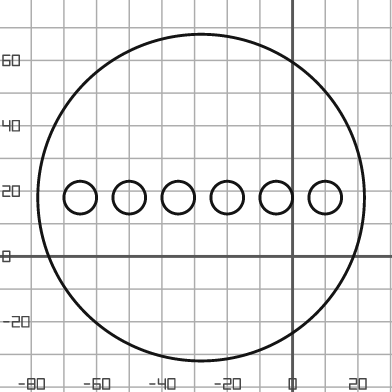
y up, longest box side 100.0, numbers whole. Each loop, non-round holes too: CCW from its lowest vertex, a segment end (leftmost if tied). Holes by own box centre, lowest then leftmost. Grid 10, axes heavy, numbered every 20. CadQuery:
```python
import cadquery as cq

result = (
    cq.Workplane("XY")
    .moveTo(-28.0, 18.0)
    .circle(50.0)
    .moveTo(-65.0, 18.0)
    .circle(5.0)
    .moveTo(-50.0, 18.0)
    .circle(5.0)
    .moveTo(-35.0, 18.0)
    .circle(5.0)
    .moveTo(-20.0, 18.0)
    .circle(5.0)
    .moveTo(-5.0, 18.0)
    .circle(5.0)
    .moveTo(10.0, 18.0)
    .circle(5.0)
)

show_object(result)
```